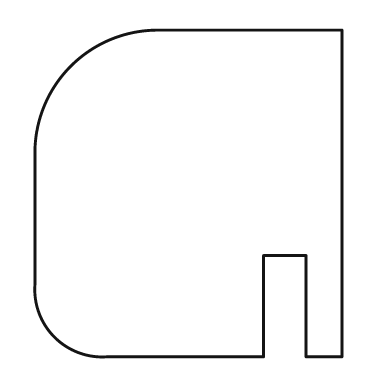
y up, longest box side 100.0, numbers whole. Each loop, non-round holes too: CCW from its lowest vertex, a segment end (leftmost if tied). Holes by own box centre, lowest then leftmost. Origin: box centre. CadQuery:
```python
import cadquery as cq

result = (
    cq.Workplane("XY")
    .moveTo(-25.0, -50.0)
    .lineTo(23.0, -50.0)
    .lineTo(23.0, -19.0)
    .lineTo(36.0, -19.0)
    .lineTo(36.0, -50.0)
    .lineTo(47.0, -50.0)
    .lineTo(47.0, 50.0)
    .lineTo(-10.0, 50.0)
    .threePointArc((-36.0, 39.0), (-47.0, 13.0))
    .lineTo(-47.0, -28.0)
    .threePointArc((-41.0, -44.0), (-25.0, -50.0))
    .close()
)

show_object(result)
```